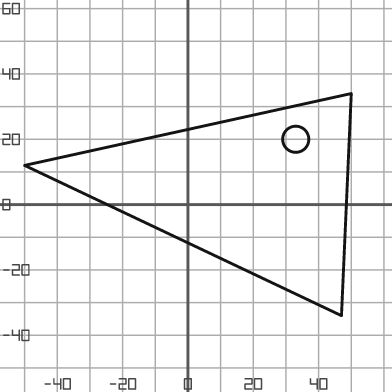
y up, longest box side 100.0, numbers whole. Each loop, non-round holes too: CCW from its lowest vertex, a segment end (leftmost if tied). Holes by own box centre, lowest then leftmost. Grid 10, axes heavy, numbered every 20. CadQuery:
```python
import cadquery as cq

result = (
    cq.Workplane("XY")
    .moveTo(47.0, -34.0)
    .lineTo(50.0, 34.0)
    .lineTo(-50.0, 12.0)
    .close()
    .moveTo(33.0, 20.0)
    .circle(4.0)
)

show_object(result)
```